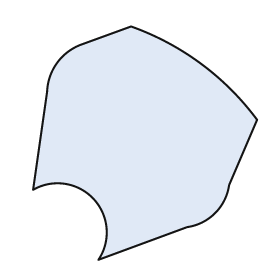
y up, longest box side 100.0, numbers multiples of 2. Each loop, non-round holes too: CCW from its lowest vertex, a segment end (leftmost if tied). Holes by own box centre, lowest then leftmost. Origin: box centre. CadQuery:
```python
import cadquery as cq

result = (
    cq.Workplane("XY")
    .moveTo(-20.0, -50.0)
    .lineTo(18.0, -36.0)
    .threePointArc((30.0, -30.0), (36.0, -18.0))
    .lineTo(48.0, 10.0)
    .threePointArc((24.0, 34.0), (-6.0, 50.0))
    .lineTo(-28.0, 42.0)
    .threePointArc((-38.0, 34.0), (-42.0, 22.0))
    .lineTo(-48.0, -20.0)
    .threePointArc((-22.0, -24.0), (-20.0, -50.0))
    .close()
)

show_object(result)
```